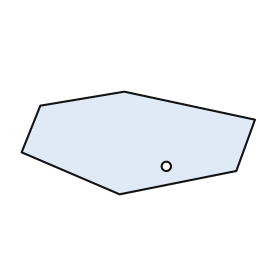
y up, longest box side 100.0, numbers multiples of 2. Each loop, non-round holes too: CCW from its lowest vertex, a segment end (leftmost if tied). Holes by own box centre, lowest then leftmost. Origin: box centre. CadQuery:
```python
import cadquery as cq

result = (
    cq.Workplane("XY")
    .moveTo(-8.0, -22.0)
    .lineTo(42.0, -12.0)
    .lineTo(50.0, 10.0)
    .lineTo(-6.0, 22.0)
    .lineTo(-42.0, 16.0)
    .lineTo(-50.0, -4.0)
    .close()
    .moveTo(12.0, -10.0)
    .circle(2.0)
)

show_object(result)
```